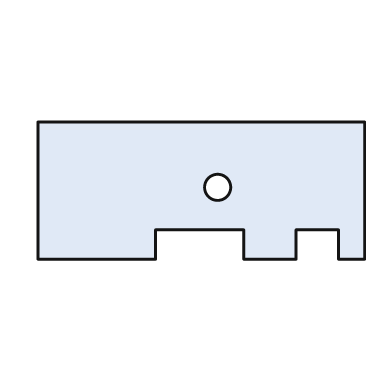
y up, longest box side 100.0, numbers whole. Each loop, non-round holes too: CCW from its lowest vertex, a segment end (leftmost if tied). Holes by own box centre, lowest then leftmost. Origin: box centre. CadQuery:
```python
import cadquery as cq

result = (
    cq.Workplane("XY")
    .moveTo(-50.0, -21.0)
    .lineTo(-14.0, -21.0)
    .lineTo(-14.0, -12.0)
    .lineTo(13.0, -12.0)
    .lineTo(13.0, -21.0)
    .lineTo(29.0, -21.0)
    .lineTo(29.0, -12.0)
    .lineTo(42.0, -12.0)
    .lineTo(42.0, -21.0)
    .lineTo(50.0, -21.0)
    .lineTo(50.0, 21.0)
    .lineTo(-50.0, 21.0)
    .close()
    .moveTo(5.0, 1.0)
    .circle(4.0)
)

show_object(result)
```